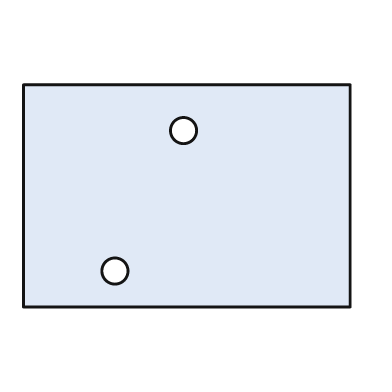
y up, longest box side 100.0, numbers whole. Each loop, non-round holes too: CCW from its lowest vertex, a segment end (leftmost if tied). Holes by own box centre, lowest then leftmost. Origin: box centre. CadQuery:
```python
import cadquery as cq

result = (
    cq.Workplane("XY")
    .moveTo(-50.0, -34.0)
    .lineTo(50.0, -34.0)
    .lineTo(50.0, 34.0)
    .lineTo(-50.0, 34.0)
    .close()
    .moveTo(-22.0, -23.0)
    .circle(4.0)
    .moveTo(-1.0, 20.0)
    .circle(4.0)
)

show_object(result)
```